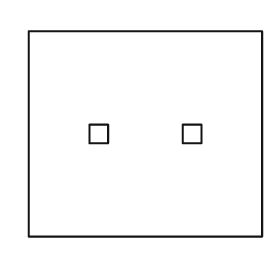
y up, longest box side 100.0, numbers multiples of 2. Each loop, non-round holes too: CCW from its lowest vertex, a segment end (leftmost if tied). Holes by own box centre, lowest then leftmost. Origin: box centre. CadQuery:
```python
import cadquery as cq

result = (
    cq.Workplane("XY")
    .moveTo(-50.0, -44.0)
    .lineTo(50.0, -44.0)
    .lineTo(50.0, 44.0)
    .lineTo(-50.0, 44.0)
    .close()
    .moveTo(-24.0, -4.0)
    .lineTo(-16.0, -4.0)
    .lineTo(-16.0, 4.0)
    .lineTo(-24.0, 4.0)
    .close()
    .moveTo(16.0, -4.0)
    .lineTo(24.0, -4.0)
    .lineTo(24.0, 4.0)
    .lineTo(16.0, 4.0)
    .close()
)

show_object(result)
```